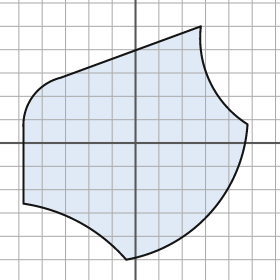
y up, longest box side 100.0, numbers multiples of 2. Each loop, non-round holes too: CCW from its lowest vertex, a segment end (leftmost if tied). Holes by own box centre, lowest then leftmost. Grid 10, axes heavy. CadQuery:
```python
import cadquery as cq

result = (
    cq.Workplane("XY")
    .moveTo(-4.0, -50.0)
    .threePointArc((32.0, -30.0), (48.0, 8.0))
    .threePointArc((32.0, 26.0), (28.0, 50.0))
    .lineTo(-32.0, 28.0)
    .threePointArc((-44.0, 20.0), (-48.0, 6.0))
    .lineTo(-48.0, -26.0)
    .threePointArc((-24.0, -34.0), (-4.0, -50.0))
    .close()
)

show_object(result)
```